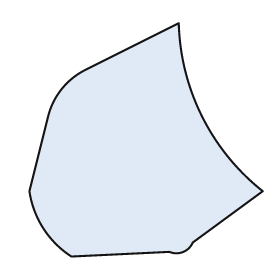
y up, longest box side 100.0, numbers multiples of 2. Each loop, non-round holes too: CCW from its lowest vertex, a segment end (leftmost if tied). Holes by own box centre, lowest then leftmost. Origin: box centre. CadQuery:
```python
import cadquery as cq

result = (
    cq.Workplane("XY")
    .moveTo(-32.0, -50.0)
    .lineTo(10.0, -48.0)
    .threePointArc((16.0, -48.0), (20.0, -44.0))
    .lineTo(50.0, -22.0)
    .threePointArc((24.0, 10.0), (14.0, 50.0))
    .lineTo(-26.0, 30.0)
    .threePointArc((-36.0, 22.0), (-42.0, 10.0))
    .lineTo(-50.0, -22.0)
    .threePointArc((-44.0, -38.0), (-32.0, -50.0))
    .close()
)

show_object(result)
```